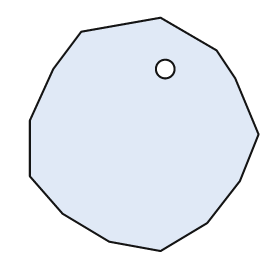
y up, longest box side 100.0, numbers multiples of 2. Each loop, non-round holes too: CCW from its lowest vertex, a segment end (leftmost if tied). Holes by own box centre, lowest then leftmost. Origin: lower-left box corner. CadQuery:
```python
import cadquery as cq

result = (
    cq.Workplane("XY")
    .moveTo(56.0, 0.0)
    .lineTo(76.0, 12.0)
    .lineTo(90.0, 30.0)
    .lineTo(98.0, 50.0)
    .lineTo(88.0, 74.0)
    .lineTo(80.0, 86.0)
    .lineTo(56.0, 100.0)
    .lineTo(22.0, 94.0)
    .lineTo(10.0, 78.0)
    .lineTo(0.0, 56.0)
    .lineTo(0.0, 32.0)
    .lineTo(14.0, 16.0)
    .lineTo(34.0, 4.0)
    .close()
    .moveTo(58.0, 78.0)
    .circle(4.0)
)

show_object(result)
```